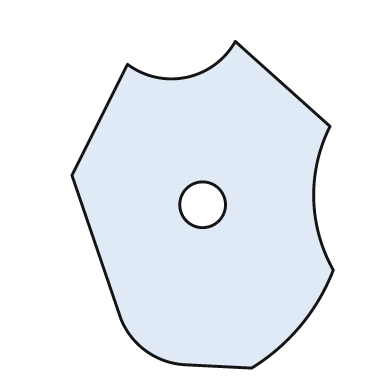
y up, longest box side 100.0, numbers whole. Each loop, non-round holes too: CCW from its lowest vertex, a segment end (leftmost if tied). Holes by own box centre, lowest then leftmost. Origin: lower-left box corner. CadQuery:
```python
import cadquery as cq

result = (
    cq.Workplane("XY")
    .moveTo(55.0, 0.0)
    .threePointArc((70.0, 13.0), (80.0, 30.0))
    .threePointArc((74.0, 52.0), (79.0, 74.0))
    .lineTo(50.0, 100.0)
    .threePointArc((35.0, 89.0), (17.0, 93.0))
    .lineTo(0.0, 59.0)
    .lineTo(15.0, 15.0)
    .threePointArc((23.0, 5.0), (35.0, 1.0))
    .close()
    .moveTo(40.0, 50.0)
    .circle(7.0)
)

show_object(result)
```